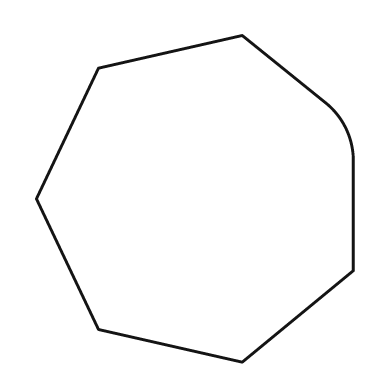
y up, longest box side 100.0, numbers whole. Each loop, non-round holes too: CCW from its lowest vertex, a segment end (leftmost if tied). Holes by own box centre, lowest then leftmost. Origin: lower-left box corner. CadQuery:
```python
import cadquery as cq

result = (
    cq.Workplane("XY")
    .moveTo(63.0, 0.0)
    .lineTo(97.0, 28.0)
    .lineTo(97.0, 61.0)
    .threePointArc((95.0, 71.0), (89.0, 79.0))
    .lineTo(63.0, 100.0)
    .lineTo(19.0, 90.0)
    .lineTo(0.0, 50.0)
    .lineTo(19.0, 10.0)
    .close()
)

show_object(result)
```